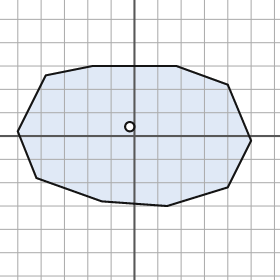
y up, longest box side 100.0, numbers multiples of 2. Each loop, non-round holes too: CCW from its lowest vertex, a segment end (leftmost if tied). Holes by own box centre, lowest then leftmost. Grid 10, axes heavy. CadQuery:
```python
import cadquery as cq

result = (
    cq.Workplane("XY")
    .moveTo(14.0, -30.0)
    .lineTo(40.0, -22.0)
    .lineTo(50.0, -2.0)
    .lineTo(40.0, 22.0)
    .lineTo(18.0, 30.0)
    .lineTo(-18.0, 30.0)
    .lineTo(-38.0, 26.0)
    .lineTo(-50.0, 2.0)
    .lineTo(-42.0, -18.0)
    .lineTo(-14.0, -28.0)
    .close()
    .moveTo(-2.0, 4.0)
    .circle(2.0)
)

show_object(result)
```